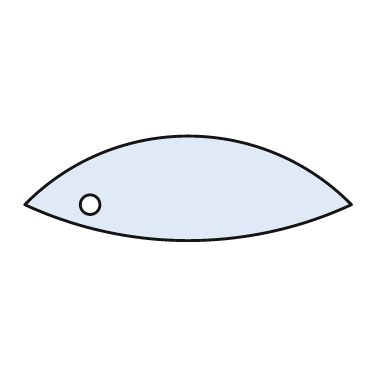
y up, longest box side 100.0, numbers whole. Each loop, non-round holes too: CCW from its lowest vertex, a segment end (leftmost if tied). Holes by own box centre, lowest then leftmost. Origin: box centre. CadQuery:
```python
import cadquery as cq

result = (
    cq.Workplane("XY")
    .moveTo(-50.0, -5.0)
    .threePointArc((0.0, -16.0), (50.0, -5.0))
    .threePointArc((0.0, 16.0), (-50.0, -5.0))
    .close()
    .moveTo(-30.0, -5.0)
    .circle(3.0)
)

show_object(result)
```